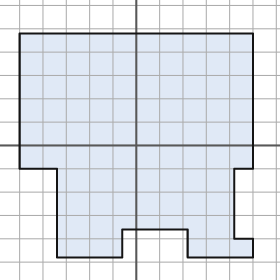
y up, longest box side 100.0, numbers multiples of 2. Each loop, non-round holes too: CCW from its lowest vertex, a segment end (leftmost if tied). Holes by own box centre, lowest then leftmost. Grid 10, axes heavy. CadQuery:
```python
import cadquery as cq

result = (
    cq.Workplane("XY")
    .moveTo(-34.0, -48.0)
    .lineTo(-6.0, -48.0)
    .lineTo(-6.0, -36.0)
    .lineTo(22.0, -36.0)
    .lineTo(22.0, -48.0)
    .lineTo(50.0, -48.0)
    .lineTo(50.0, -40.0)
    .lineTo(42.0, -40.0)
    .lineTo(42.0, -10.0)
    .lineTo(50.0, -10.0)
    .lineTo(50.0, 48.0)
    .lineTo(-50.0, 48.0)
    .lineTo(-50.0, -10.0)
    .lineTo(-34.0, -10.0)
    .close()
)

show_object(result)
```